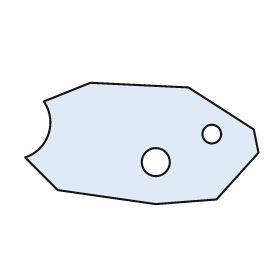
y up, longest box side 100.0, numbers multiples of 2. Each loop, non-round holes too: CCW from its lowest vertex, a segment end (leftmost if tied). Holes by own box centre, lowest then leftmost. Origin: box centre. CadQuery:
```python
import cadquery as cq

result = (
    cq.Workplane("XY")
    .moveTo(6.0, -26.0)
    .lineTo(32.0, -24.0)
    .lineTo(50.0, -4.0)
    .lineTo(48.0, 6.0)
    .lineTo(20.0, 24.0)
    .lineTo(-22.0, 26.0)
    .lineTo(-42.0, 18.0)
    .threePointArc((-40.0, 4.0), (-50.0, -6.0))
    .lineTo(-36.0, -20.0)
    .close()
    .moveTo(6.0, -8.0)
    .circle(6.0)
    .moveTo(30.0, 4.0)
    .circle(4.0)
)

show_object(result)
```